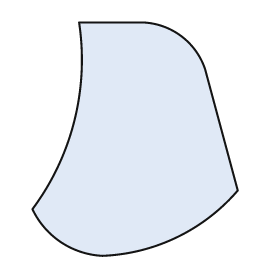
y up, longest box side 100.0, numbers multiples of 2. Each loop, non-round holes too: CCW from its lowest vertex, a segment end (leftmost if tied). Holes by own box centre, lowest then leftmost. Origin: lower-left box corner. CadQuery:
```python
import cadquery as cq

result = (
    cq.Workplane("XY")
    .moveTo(30.0, 0.0)
    .threePointArc((62.0, 8.0), (88.0, 28.0))
    .lineTo(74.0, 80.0)
    .threePointArc((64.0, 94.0), (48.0, 100.0))
    .lineTo(20.0, 100.0)
    .threePointArc((18.0, 58.0), (0.0, 20.0))
    .threePointArc((12.0, 6.0), (30.0, 0.0))
    .close()
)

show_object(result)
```